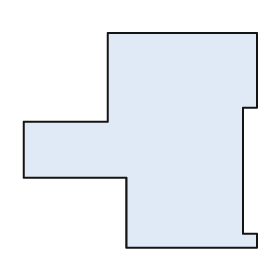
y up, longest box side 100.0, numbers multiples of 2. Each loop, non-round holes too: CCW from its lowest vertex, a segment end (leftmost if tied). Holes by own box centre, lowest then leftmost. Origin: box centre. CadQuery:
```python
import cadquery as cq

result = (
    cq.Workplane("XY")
    .moveTo(-6.0, -46.0)
    .lineTo(50.0, -46.0)
    .lineTo(50.0, -40.0)
    .lineTo(44.0, -40.0)
    .lineTo(44.0, 14.0)
    .lineTo(50.0, 14.0)
    .lineTo(50.0, 46.0)
    .lineTo(-14.0, 46.0)
    .lineTo(-14.0, 8.0)
    .lineTo(-50.0, 8.0)
    .lineTo(-50.0, -16.0)
    .lineTo(-6.0, -16.0)
    .close()
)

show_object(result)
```